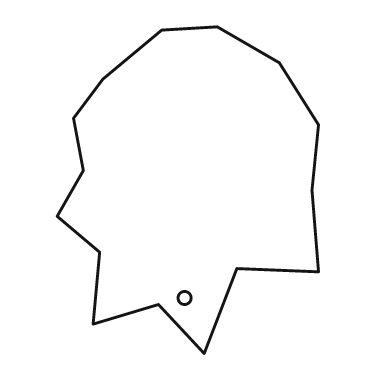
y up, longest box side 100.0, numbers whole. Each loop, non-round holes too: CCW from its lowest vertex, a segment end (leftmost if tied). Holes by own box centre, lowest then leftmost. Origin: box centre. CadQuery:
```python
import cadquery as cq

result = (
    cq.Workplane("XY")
    .moveTo(5.0, -50.0)
    .lineTo(15.0, -24.0)
    .lineTo(40.0, -25.0)
    .lineTo(38.0, 0.0)
    .lineTo(40.0, 20.0)
    .lineTo(28.0, 39.0)
    .lineTo(9.0, 50.0)
    .lineTo(-8.0, 49.0)
    .lineTo(-26.0, 34.0)
    .lineTo(-35.0, 22.0)
    .lineTo(-32.0, 6.0)
    .lineTo(-40.0, -8.0)
    .lineTo(-27.0, -19.0)
    .lineTo(-29.0, -41.0)
    .lineTo(-9.0, -35.0)
    .close()
    .moveTo(-1.0, -33.0)
    .circle(2.0)
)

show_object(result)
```